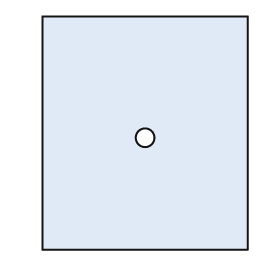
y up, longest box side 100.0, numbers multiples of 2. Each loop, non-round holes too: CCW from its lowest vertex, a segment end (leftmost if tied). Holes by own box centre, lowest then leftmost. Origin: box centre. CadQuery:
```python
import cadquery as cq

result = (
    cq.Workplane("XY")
    .moveTo(-44.0, -50.0)
    .lineTo(44.0, -50.0)
    .lineTo(44.0, 50.0)
    .lineTo(-44.0, 50.0)
    .close()
    .moveTo(0.0, -2.0)
    .circle(4.0)
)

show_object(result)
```